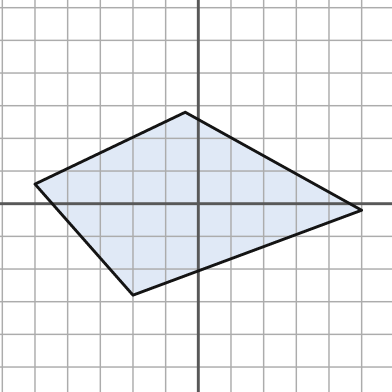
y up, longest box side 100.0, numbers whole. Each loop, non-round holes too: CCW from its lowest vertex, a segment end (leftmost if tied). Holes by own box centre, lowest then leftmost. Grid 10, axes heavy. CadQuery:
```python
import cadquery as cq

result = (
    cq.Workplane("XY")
    .moveTo(-20.0, -28.0)
    .lineTo(50.0, -2.0)
    .lineTo(-4.0, 28.0)
    .lineTo(-50.0, 6.0)
    .close()
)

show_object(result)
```